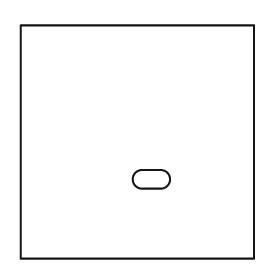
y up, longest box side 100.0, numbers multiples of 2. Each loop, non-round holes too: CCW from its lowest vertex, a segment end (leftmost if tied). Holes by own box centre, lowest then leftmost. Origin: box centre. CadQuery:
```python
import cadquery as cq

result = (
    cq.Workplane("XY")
    .moveTo(-50.0, -50.0)
    .lineTo(50.0, -50.0)
    .lineTo(50.0, 50.0)
    .lineTo(-50.0, 50.0)
    .close()
    .moveTo(2.0, -20.0)
    .lineTo(10.0, -20.0)
    .threePointArc((14.0, -16.0), (10.0, -12.0))
    .lineTo(2.0, -12.0)
    .threePointArc((-2.0, -16.0), (2.0, -20.0))
    .close()
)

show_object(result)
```